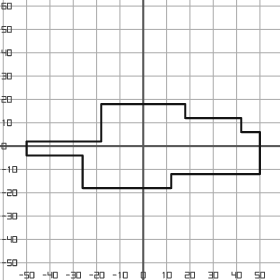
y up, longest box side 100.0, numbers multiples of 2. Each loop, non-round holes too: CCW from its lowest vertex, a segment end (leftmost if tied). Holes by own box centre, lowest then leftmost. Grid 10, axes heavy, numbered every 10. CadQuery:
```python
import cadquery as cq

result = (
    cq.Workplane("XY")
    .moveTo(-26.0, -18.0)
    .lineTo(12.0, -18.0)
    .lineTo(12.0, -12.0)
    .lineTo(50.0, -12.0)
    .lineTo(50.0, 6.0)
    .lineTo(42.0, 6.0)
    .lineTo(42.0, 12.0)
    .lineTo(18.0, 12.0)
    .lineTo(18.0, 18.0)
    .lineTo(-18.0, 18.0)
    .lineTo(-18.0, 2.0)
    .lineTo(-50.0, 2.0)
    .lineTo(-50.0, -4.0)
    .lineTo(-26.0, -4.0)
    .close()
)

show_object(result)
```